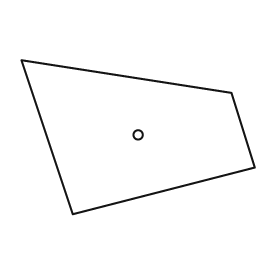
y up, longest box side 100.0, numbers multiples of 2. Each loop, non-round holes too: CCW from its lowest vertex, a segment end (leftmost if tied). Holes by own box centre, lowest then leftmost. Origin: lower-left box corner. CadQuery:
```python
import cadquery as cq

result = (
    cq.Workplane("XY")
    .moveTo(22.0, 0.0)
    .lineTo(100.0, 20.0)
    .lineTo(90.0, 52.0)
    .lineTo(0.0, 66.0)
    .close()
    .moveTo(50.0, 34.0)
    .circle(2.0)
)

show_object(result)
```